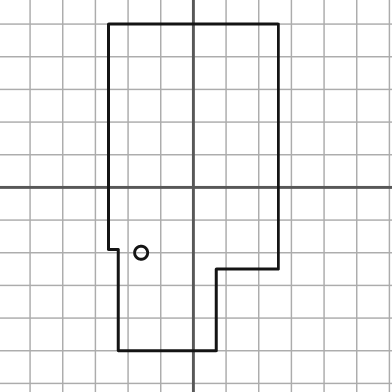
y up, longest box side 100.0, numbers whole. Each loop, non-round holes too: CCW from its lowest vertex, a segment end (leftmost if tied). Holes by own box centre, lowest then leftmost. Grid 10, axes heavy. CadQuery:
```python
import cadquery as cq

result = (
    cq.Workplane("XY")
    .moveTo(-23.0, -50.0)
    .lineTo(7.0, -50.0)
    .lineTo(7.0, -25.0)
    .lineTo(26.0, -25.0)
    .lineTo(26.0, 50.0)
    .lineTo(-26.0, 50.0)
    .lineTo(-26.0, -19.0)
    .lineTo(-23.0, -19.0)
    .close()
    .moveTo(-16.0, -20.0)
    .circle(2.0)
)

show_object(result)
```